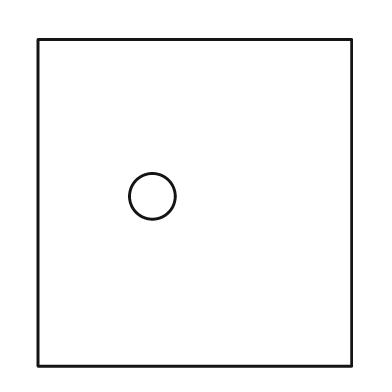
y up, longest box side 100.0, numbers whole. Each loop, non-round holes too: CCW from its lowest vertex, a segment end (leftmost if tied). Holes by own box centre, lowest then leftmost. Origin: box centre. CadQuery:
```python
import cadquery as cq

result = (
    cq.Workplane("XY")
    .moveTo(-48.0, -50.0)
    .lineTo(48.0, -50.0)
    .lineTo(48.0, 50.0)
    .lineTo(-48.0, 50.0)
    .close()
    .moveTo(-13.0, 2.0)
    .circle(7.0)
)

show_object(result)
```